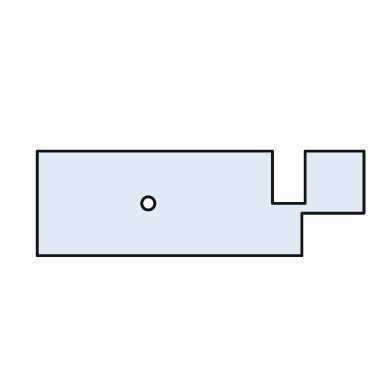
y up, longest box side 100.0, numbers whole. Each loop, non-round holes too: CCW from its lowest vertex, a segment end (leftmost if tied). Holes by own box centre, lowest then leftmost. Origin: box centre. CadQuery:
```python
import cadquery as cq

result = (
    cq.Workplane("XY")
    .moveTo(-50.0, -16.0)
    .lineTo(31.0, -16.0)
    .lineTo(31.0, -3.0)
    .lineTo(50.0, -3.0)
    .lineTo(50.0, 16.0)
    .lineTo(32.0, 16.0)
    .lineTo(32.0, 0.0)
    .lineTo(22.0, 0.0)
    .lineTo(22.0, 16.0)
    .lineTo(-50.0, 16.0)
    .close()
    .moveTo(-16.0, 0.0)
    .circle(2.0)
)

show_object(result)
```